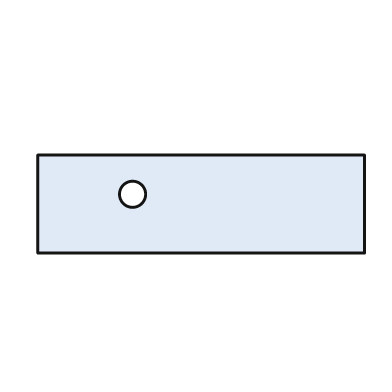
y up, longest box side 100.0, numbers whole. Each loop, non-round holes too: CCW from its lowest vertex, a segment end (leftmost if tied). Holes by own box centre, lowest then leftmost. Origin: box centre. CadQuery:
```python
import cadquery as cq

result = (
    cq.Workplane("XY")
    .moveTo(-50.0, -15.0)
    .lineTo(50.0, -15.0)
    .lineTo(50.0, 15.0)
    .lineTo(-50.0, 15.0)
    .close()
    .moveTo(-21.0, 3.0)
    .circle(4.0)
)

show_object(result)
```